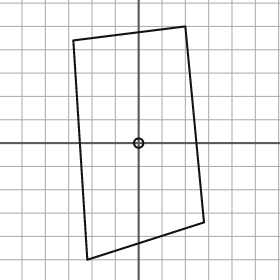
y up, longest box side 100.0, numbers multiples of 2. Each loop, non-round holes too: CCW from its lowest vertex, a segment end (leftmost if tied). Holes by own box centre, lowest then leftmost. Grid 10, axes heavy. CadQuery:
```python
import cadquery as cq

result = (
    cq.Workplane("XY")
    .moveTo(-22.0, -50.0)
    .lineTo(28.0, -34.0)
    .lineTo(20.0, 50.0)
    .lineTo(-28.0, 44.0)
    .close()
    .moveTo(0.0, 0.0)
    .circle(2.0)
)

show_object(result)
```